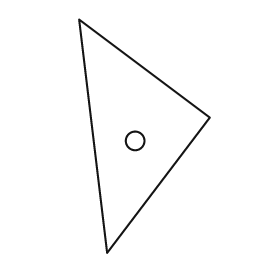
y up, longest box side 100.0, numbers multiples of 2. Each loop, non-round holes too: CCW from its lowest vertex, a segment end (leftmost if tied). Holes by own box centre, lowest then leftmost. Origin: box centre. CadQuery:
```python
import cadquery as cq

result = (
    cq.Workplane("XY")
    .moveTo(-16.0, -50.0)
    .lineTo(28.0, 8.0)
    .lineTo(-28.0, 50.0)
    .close()
    .moveTo(-4.0, -2.0)
    .circle(4.0)
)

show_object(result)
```